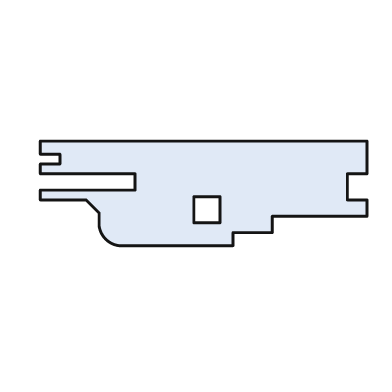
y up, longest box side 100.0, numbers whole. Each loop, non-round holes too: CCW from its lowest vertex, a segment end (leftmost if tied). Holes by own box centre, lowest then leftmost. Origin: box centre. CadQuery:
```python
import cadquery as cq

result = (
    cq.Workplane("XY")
    .moveTo(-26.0, -16.0)
    .lineTo(9.0, -16.0)
    .lineTo(9.0, -12.0)
    .lineTo(21.0, -12.0)
    .lineTo(21.0, -7.0)
    .lineTo(50.0, -7.0)
    .lineTo(50.0, -2.0)
    .lineTo(44.0, -2.0)
    .lineTo(44.0, 6.0)
    .lineTo(50.0, 6.0)
    .lineTo(50.0, 16.0)
    .lineTo(-50.0, 16.0)
    .lineTo(-50.0, 12.0)
    .lineTo(-44.0, 12.0)
    .lineTo(-44.0, 9.0)
    .lineTo(-50.0, 9.0)
    .lineTo(-50.0, 6.0)
    .lineTo(-21.0, 6.0)
    .lineTo(-21.0, 1.0)
    .lineTo(-50.0, 1.0)
    .lineTo(-50.0, -2.0)
    .lineTo(-36.0, -2.0)
    .lineTo(-32.0, -6.0)
    .lineTo(-32.0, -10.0)
    .threePointArc((-30.0, -14.0), (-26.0, -16.0))
    .close()
    .moveTo(-3.0, -9.0)
    .lineTo(5.0, -9.0)
    .lineTo(5.0, -1.0)
    .lineTo(-3.0, -1.0)
    .close()
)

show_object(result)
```